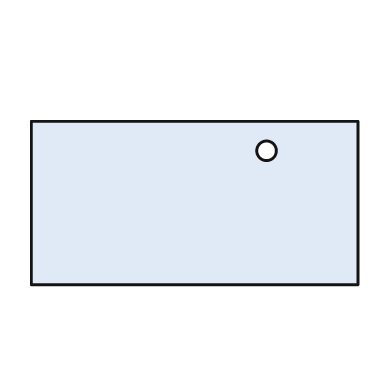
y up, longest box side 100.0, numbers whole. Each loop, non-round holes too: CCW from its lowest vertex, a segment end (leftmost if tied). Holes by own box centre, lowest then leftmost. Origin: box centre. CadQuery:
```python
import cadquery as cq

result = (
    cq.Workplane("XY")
    .moveTo(-50.0, -25.0)
    .lineTo(50.0, -25.0)
    .lineTo(50.0, 25.0)
    .lineTo(-50.0, 25.0)
    .close()
    .moveTo(22.0, 16.0)
    .circle(3.0)
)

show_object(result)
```